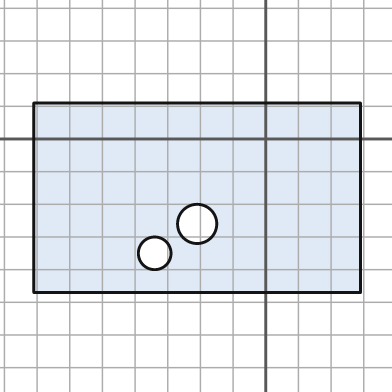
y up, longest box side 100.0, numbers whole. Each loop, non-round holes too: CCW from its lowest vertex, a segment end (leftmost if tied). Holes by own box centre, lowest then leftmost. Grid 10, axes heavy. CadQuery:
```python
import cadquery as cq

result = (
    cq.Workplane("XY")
    .moveTo(-71.0, -47.0)
    .lineTo(29.0, -47.0)
    .lineTo(29.0, 11.0)
    .lineTo(-71.0, 11.0)
    .close()
    .moveTo(-34.0, -35.0)
    .circle(5.0)
    .moveTo(-21.0, -26.0)
    .circle(6.0)
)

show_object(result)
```